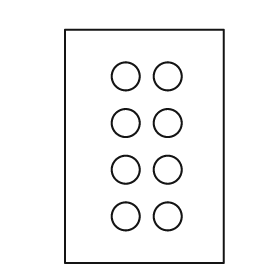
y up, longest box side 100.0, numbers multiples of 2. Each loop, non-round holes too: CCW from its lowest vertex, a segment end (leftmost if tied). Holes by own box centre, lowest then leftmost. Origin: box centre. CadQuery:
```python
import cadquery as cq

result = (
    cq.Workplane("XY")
    .moveTo(-34.0, -50.0)
    .lineTo(34.0, -50.0)
    .lineTo(34.0, 50.0)
    .lineTo(-34.0, 50.0)
    .close()
    .moveTo(-8.0, -30.0)
    .circle(6.0)
    .moveTo(10.0, -30.0)
    .circle(6.0)
    .moveTo(-8.0, -10.0)
    .circle(6.0)
    .moveTo(10.0, -10.0)
    .circle(6.0)
    .moveTo(-8.0, 10.0)
    .circle(6.0)
    .moveTo(10.0, 10.0)
    .circle(6.0)
    .moveTo(-8.0, 30.0)
    .circle(6.0)
    .moveTo(10.0, 30.0)
    .circle(6.0)
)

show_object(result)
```